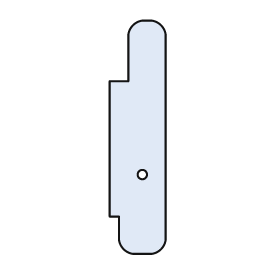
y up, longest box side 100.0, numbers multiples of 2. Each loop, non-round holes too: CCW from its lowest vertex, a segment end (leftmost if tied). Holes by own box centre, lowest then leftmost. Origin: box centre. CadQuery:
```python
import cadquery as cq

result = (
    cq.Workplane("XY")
    .moveTo(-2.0, -50.0)
    .lineTo(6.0, -50.0)
    .threePointArc((10.0, -48.0), (12.0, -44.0))
    .lineTo(12.0, 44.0)
    .threePointArc((10.0, 48.0), (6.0, 50.0))
    .lineTo(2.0, 50.0)
    .threePointArc((-2.0, 48.0), (-4.0, 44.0))
    .lineTo(-4.0, 24.0)
    .lineTo(-12.0, 24.0)
    .lineTo(-12.0, -34.0)
    .lineTo(-8.0, -34.0)
    .lineTo(-8.0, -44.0)
    .threePointArc((-6.0, -48.0), (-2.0, -50.0))
    .close()
    .moveTo(2.0, -16.0)
    .circle(2.0)
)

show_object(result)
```